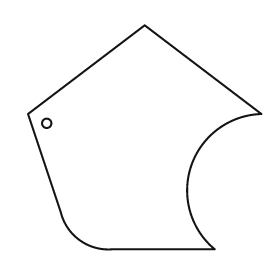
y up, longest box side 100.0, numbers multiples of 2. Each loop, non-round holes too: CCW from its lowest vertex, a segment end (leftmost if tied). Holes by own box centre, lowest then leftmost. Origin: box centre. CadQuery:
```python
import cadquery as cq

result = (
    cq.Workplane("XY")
    .moveTo(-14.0, -48.0)
    .lineTo(30.0, -48.0)
    .threePointArc((20.0, -12.0), (50.0, 10.0))
    .lineTo(0.0, 48.0)
    .lineTo(-50.0, 10.0)
    .lineTo(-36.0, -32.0)
    .threePointArc((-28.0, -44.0), (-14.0, -48.0))
    .close()
    .moveTo(-42.0, 6.0)
    .circle(2.0)
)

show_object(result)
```